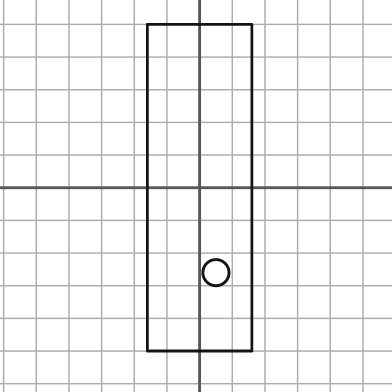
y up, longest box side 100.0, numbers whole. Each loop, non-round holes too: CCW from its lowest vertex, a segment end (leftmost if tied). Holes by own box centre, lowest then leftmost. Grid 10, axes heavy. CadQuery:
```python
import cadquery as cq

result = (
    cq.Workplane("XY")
    .moveTo(-16.0, -50.0)
    .lineTo(16.0, -50.0)
    .lineTo(16.0, 50.0)
    .lineTo(-16.0, 50.0)
    .close()
    .moveTo(5.0, -26.0)
    .circle(4.0)
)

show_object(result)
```